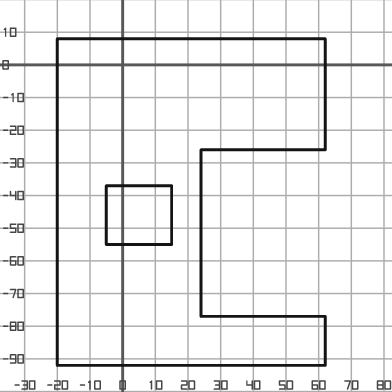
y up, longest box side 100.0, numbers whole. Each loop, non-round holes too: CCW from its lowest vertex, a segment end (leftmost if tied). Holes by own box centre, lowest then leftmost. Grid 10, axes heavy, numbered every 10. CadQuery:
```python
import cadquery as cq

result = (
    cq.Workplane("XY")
    .moveTo(-20.0, -92.0)
    .lineTo(62.0, -92.0)
    .lineTo(62.0, -77.0)
    .lineTo(24.0, -77.0)
    .lineTo(24.0, -26.0)
    .lineTo(62.0, -26.0)
    .lineTo(62.0, 8.0)
    .lineTo(-20.0, 8.0)
    .close()
    .moveTo(-5.0, -55.0)
    .lineTo(15.0, -55.0)
    .lineTo(15.0, -37.0)
    .lineTo(-5.0, -37.0)
    .close()
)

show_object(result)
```